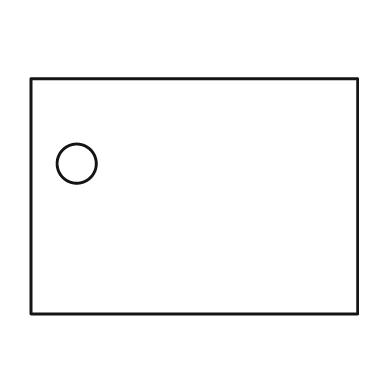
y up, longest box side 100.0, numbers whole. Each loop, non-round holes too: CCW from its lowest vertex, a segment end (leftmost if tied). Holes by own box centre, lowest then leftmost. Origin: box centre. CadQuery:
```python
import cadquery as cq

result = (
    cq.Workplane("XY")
    .moveTo(-50.0, -36.0)
    .lineTo(50.0, -36.0)
    .lineTo(50.0, 36.0)
    .lineTo(-50.0, 36.0)
    .close()
    .moveTo(-36.0, 10.0)
    .circle(6.0)
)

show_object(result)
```